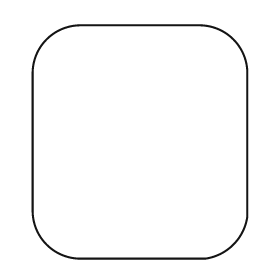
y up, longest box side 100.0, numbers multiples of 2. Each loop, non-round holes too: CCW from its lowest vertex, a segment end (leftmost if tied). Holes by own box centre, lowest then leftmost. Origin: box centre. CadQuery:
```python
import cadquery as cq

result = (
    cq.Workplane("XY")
    .moveTo(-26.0, -50.0)
    .lineTo(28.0, -50.0)
    .threePointArc((40.0, -44.0), (46.0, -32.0))
    .lineTo(46.0, 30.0)
    .threePointArc((40.0, 44.0), (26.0, 50.0))
    .lineTo(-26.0, 50.0)
    .threePointArc((-40.0, 44.0), (-46.0, 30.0))
    .lineTo(-46.0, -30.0)
    .threePointArc((-40.0, -44.0), (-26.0, -50.0))
    .close()
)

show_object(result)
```